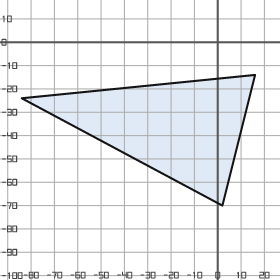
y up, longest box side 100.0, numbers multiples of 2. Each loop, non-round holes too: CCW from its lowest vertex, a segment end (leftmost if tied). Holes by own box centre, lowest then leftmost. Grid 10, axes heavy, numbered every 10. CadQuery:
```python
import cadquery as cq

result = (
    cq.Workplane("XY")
    .moveTo(2.0, -70.0)
    .lineTo(16.0, -14.0)
    .lineTo(-84.0, -24.0)
    .close()
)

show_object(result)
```